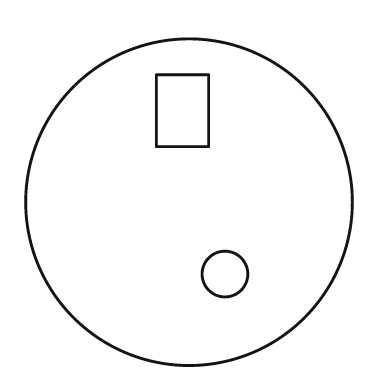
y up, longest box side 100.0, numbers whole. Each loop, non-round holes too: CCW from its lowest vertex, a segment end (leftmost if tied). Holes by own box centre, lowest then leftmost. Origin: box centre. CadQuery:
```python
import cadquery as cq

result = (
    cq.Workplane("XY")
    .moveTo(0.0, 0.0)
    .circle(50.0)
    .moveTo(11.0, -22.0)
    .circle(7.0)
    .moveTo(-10.0, 17.0)
    .lineTo(6.0, 17.0)
    .lineTo(6.0, 39.0)
    .lineTo(-10.0, 39.0)
    .close()
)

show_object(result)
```